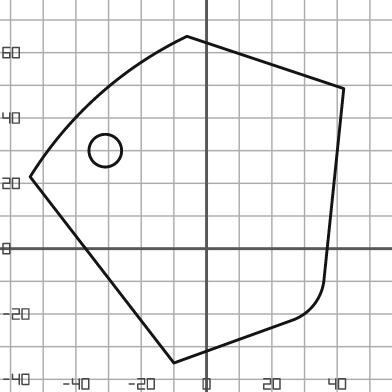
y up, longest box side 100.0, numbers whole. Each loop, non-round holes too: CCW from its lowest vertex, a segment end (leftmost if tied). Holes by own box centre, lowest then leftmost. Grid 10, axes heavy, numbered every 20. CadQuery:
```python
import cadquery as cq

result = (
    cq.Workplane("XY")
    .moveTo(-10.0, -35.0)
    .lineTo(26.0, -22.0)
    .threePointArc((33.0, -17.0), (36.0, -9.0))
    .lineTo(42.0, 49.0)
    .lineTo(-6.0, 65.0)
    .threePointArc((-33.0, 47.0), (-54.0, 22.0))
    .close()
    .moveTo(-31.0, 30.0)
    .circle(5.0)
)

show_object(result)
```